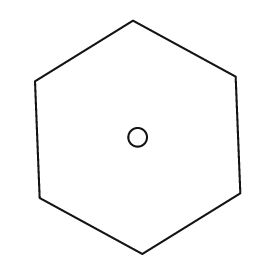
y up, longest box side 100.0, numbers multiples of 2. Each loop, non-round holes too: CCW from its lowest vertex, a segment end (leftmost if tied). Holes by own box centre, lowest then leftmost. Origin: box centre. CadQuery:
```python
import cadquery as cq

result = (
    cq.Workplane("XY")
    .moveTo(2.0, -50.0)
    .lineTo(44.0, -24.0)
    .lineTo(42.0, 26.0)
    .lineTo(-2.0, 50.0)
    .lineTo(-44.0, 24.0)
    .lineTo(-42.0, -26.0)
    .close()
    .moveTo(0.0, 0.0)
    .circle(4.0)
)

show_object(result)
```